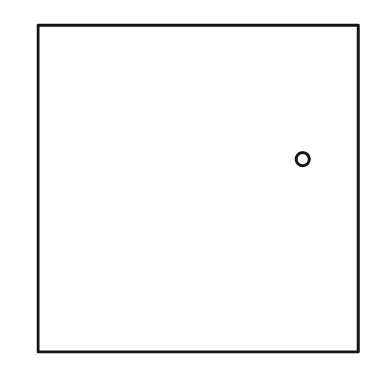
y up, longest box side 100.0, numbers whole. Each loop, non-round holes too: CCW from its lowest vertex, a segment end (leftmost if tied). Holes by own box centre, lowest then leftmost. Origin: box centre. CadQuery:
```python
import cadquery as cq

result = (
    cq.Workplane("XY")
    .moveTo(-49.0, -50.0)
    .lineTo(49.0, -50.0)
    .lineTo(49.0, 50.0)
    .lineTo(-49.0, 50.0)
    .close()
    .moveTo(32.0, 9.0)
    .circle(2.0)
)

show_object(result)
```